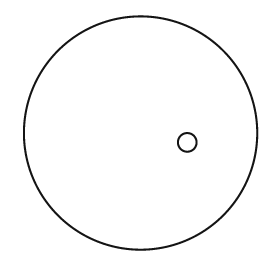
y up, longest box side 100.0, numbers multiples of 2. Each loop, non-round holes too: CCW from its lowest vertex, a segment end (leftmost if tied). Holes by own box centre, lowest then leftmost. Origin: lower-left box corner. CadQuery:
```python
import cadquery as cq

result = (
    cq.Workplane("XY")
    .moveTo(50.0, 50.0)
    .circle(50.0)
    .moveTo(70.0, 46.0)
    .circle(4.0)
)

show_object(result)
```